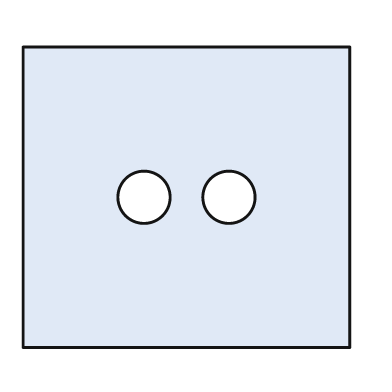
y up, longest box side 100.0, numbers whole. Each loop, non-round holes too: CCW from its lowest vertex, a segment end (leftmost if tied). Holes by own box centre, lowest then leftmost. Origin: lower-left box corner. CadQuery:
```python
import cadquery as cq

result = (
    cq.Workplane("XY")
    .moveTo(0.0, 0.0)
    .lineTo(100.0, 0.0)
    .lineTo(100.0, 92.0)
    .lineTo(0.0, 92.0)
    .close()
    .moveTo(37.0, 46.0)
    .circle(8.0)
    .moveTo(63.0, 46.0)
    .circle(8.0)
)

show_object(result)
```